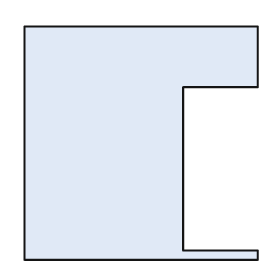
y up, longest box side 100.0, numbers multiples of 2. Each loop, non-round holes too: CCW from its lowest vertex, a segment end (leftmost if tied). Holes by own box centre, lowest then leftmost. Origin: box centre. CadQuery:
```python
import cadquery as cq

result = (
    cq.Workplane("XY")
    .moveTo(-50.0, -50.0)
    .lineTo(50.0, -50.0)
    .lineTo(50.0, -46.0)
    .lineTo(18.0, -46.0)
    .lineTo(18.0, 24.0)
    .lineTo(50.0, 24.0)
    .lineTo(50.0, 50.0)
    .lineTo(-50.0, 50.0)
    .close()
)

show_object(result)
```